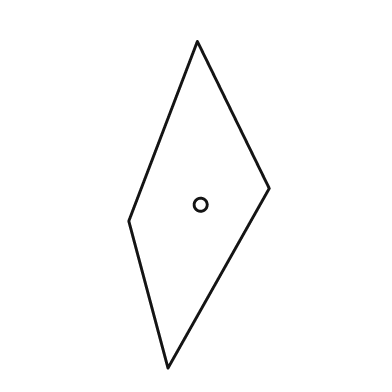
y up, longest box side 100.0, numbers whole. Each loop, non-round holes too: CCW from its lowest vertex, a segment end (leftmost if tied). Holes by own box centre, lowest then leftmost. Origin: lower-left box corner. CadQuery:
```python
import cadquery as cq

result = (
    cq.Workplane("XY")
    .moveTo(12.0, 0.0)
    .lineTo(43.0, 55.0)
    .lineTo(21.0, 100.0)
    .lineTo(0.0, 45.0)
    .close()
    .moveTo(22.0, 50.0)
    .circle(2.0)
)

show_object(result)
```